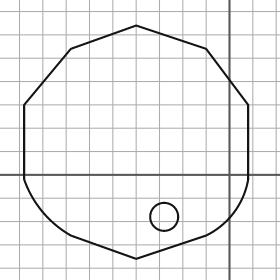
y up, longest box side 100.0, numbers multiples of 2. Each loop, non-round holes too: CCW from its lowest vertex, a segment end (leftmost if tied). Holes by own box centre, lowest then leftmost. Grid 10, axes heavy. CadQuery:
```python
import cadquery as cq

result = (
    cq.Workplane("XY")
    .moveTo(-40.0, -36.0)
    .lineTo(-10.0, -26.0)
    .threePointArc((2.0, -16.0), (8.0, -2.0))
    .lineTo(8.0, 30.0)
    .lineTo(-10.0, 54.0)
    .lineTo(-40.0, 64.0)
    .lineTo(-68.0, 54.0)
    .lineTo(-88.0, 30.0)
    .lineTo(-88.0, -2.0)
    .threePointArc((-80.0, -16.0), (-68.0, -26.0))
    .close()
    .moveTo(-28.0, -18.0)
    .circle(6.0)
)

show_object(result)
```